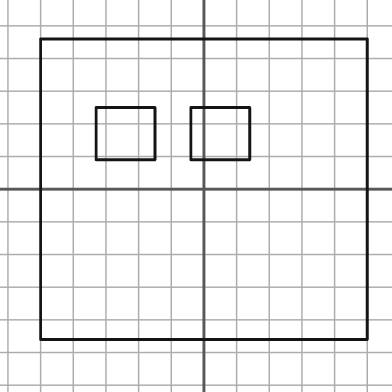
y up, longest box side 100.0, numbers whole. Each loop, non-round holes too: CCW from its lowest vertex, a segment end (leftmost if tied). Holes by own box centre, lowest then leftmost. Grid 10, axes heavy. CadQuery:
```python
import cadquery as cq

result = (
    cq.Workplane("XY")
    .moveTo(-50.0, -46.0)
    .lineTo(50.0, -46.0)
    .lineTo(50.0, 46.0)
    .lineTo(-50.0, 46.0)
    .close()
    .moveTo(-33.0, 9.0)
    .lineTo(-15.0, 9.0)
    .lineTo(-15.0, 25.0)
    .lineTo(-33.0, 25.0)
    .close()
    .moveTo(-4.0, 9.0)
    .lineTo(14.0, 9.0)
    .lineTo(14.0, 25.0)
    .lineTo(-4.0, 25.0)
    .close()
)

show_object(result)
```